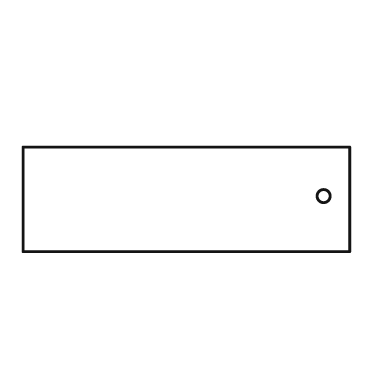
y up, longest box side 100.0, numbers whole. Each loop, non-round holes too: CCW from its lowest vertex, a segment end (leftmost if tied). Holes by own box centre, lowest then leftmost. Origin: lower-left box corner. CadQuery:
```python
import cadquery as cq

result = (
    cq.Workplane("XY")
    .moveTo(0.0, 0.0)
    .lineTo(100.0, 0.0)
    .lineTo(100.0, 32.0)
    .lineTo(0.0, 32.0)
    .close()
    .moveTo(92.0, 17.0)
    .circle(2.0)
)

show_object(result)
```